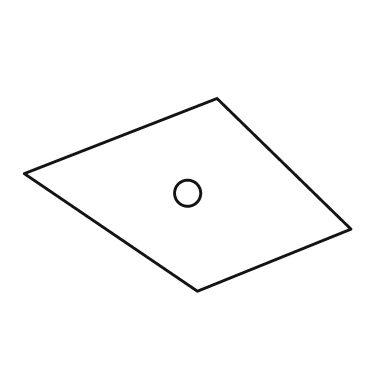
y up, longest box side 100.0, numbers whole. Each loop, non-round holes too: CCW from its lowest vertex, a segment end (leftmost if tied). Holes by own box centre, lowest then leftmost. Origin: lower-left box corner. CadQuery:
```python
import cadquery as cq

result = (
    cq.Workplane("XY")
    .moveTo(53.0, 0.0)
    .lineTo(100.0, 19.0)
    .lineTo(59.0, 59.0)
    .lineTo(0.0, 36.0)
    .close()
    .moveTo(50.0, 30.0)
    .circle(4.0)
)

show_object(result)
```